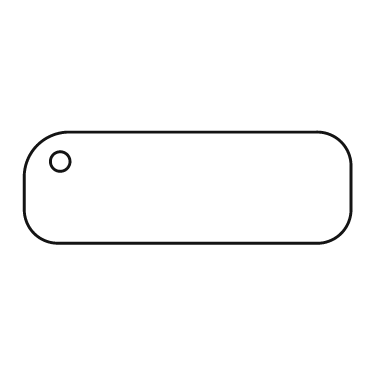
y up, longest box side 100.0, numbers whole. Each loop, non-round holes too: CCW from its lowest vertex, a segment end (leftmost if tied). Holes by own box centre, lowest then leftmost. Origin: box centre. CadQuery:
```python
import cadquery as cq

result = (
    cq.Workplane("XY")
    .moveTo(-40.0, -17.0)
    .lineTo(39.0, -17.0)
    .threePointArc((47.0, -14.0), (50.0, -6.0))
    .lineTo(50.0, 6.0)
    .threePointArc((47.0, 14.0), (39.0, 17.0))
    .lineTo(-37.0, 17.0)
    .threePointArc((-46.0, 13.0), (-50.0, 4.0))
    .lineTo(-50.0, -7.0)
    .threePointArc((-47.0, -14.0), (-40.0, -17.0))
    .close()
    .moveTo(-39.0, 8.0)
    .circle(3.0)
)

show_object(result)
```